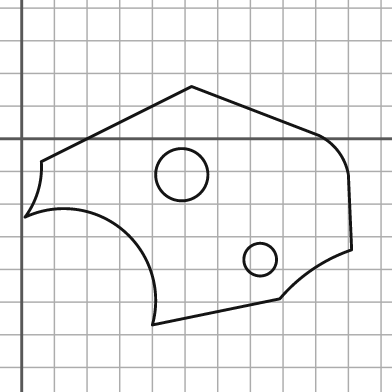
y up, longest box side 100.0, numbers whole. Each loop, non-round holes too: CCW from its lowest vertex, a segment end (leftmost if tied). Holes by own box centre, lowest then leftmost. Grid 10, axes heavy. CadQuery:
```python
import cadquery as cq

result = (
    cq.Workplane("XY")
    .moveTo(40.0, -57.0)
    .lineTo(79.0, -49.0)
    .threePointArc((89.0, -40.0), (101.0, -34.0))
    .lineTo(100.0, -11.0)
    .threePointArc((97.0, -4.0), (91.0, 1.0))
    .lineTo(52.0, 16.0)
    .lineTo(6.0, -7.0)
    .threePointArc((5.0, -16.0), (1.0, -24.0))
    .threePointArc((31.0, -28.0), (40.0, -57.0))
    .close()
    .moveTo(73.0, -37.0)
    .circle(5.0)
    .moveTo(49.0, -11.0)
    .circle(8.0)
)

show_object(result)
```